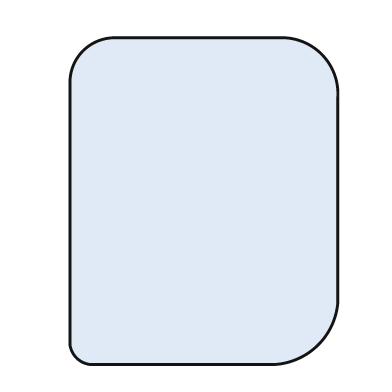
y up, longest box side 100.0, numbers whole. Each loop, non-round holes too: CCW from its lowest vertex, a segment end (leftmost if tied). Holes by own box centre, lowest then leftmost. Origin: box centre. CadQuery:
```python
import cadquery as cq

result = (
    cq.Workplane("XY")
    .moveTo(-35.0, -50.0)
    .lineTo(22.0, -50.0)
    .threePointArc((35.0, -44.0), (41.0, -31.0))
    .lineTo(41.0, 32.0)
    .threePointArc((36.0, 45.0), (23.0, 50.0))
    .lineTo(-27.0, 50.0)
    .threePointArc((-37.0, 46.0), (-41.0, 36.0))
    .lineTo(-41.0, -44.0)
    .threePointArc((-39.0, -48.0), (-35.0, -50.0))
    .close()
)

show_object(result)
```